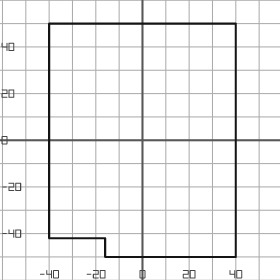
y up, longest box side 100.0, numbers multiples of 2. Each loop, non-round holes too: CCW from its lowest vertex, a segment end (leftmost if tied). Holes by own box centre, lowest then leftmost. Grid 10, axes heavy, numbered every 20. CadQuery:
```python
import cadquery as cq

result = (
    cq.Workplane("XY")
    .moveTo(-16.0, -50.0)
    .lineTo(40.0, -50.0)
    .lineTo(40.0, 50.0)
    .lineTo(-40.0, 50.0)
    .lineTo(-40.0, -42.0)
    .lineTo(-16.0, -42.0)
    .close()
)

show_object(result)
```